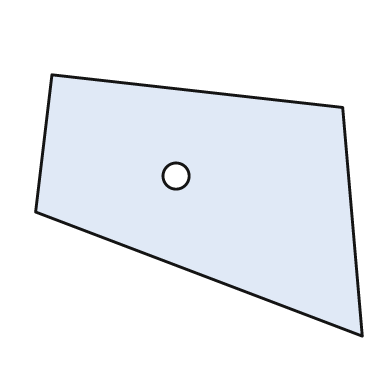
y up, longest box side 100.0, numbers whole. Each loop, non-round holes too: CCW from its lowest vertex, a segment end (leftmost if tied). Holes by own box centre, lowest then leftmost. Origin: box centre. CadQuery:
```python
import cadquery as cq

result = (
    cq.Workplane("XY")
    .moveTo(50.0, -40.0)
    .lineTo(44.0, 30.0)
    .lineTo(-45.0, 40.0)
    .lineTo(-50.0, -2.0)
    .close()
    .moveTo(-7.0, 9.0)
    .circle(4.0)
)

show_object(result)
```